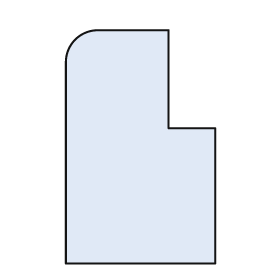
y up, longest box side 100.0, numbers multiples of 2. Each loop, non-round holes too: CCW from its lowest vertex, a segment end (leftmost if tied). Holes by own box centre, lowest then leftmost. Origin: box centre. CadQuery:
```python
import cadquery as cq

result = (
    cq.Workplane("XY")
    .moveTo(-32.0, -50.0)
    .lineTo(32.0, -50.0)
    .lineTo(32.0, 8.0)
    .lineTo(12.0, 8.0)
    .lineTo(12.0, 50.0)
    .lineTo(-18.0, 50.0)
    .threePointArc((-28.0, 46.0), (-32.0, 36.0))
    .close()
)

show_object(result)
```